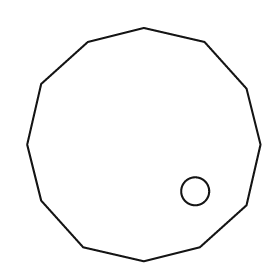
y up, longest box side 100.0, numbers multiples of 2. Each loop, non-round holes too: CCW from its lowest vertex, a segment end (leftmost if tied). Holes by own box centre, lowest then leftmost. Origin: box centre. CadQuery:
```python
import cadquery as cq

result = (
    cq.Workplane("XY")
    .moveTo(0.0, -50.0)
    .lineTo(24.0, -44.0)
    .lineTo(44.0, -26.0)
    .lineTo(50.0, 0.0)
    .lineTo(44.0, 24.0)
    .lineTo(26.0, 44.0)
    .lineTo(0.0, 50.0)
    .lineTo(-24.0, 44.0)
    .lineTo(-44.0, 26.0)
    .lineTo(-50.0, 0.0)
    .lineTo(-44.0, -24.0)
    .lineTo(-26.0, -44.0)
    .close()
    .moveTo(22.0, -20.0)
    .circle(6.0)
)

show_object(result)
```